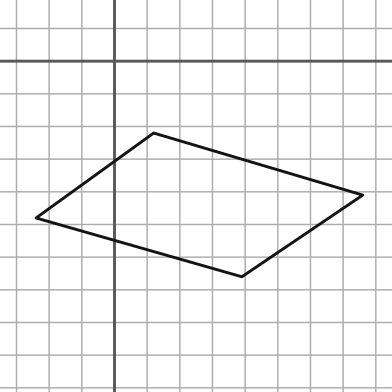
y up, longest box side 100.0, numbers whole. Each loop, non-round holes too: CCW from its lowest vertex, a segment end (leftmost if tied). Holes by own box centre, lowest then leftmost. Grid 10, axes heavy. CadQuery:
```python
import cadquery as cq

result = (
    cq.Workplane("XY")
    .moveTo(39.0, -66.0)
    .lineTo(76.0, -41.0)
    .lineTo(12.0, -22.0)
    .lineTo(-24.0, -48.0)
    .close()
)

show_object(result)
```